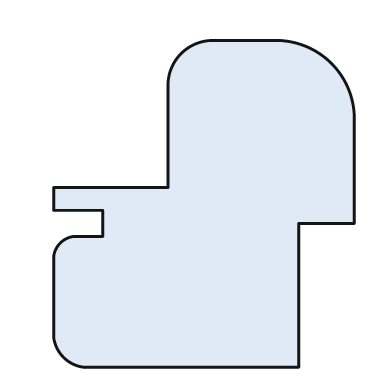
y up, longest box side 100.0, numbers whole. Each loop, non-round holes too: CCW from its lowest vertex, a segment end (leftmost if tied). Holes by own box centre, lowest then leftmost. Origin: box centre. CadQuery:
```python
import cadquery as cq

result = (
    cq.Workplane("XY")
    .moveTo(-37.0, -50.0)
    .lineTo(29.0, -50.0)
    .lineTo(29.0, -6.0)
    .lineTo(46.0, -6.0)
    .lineTo(46.0, 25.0)
    .threePointArc((39.0, 43.0), (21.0, 50.0))
    .lineTo(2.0, 50.0)
    .threePointArc((-7.0, 46.0), (-11.0, 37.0))
    .lineTo(-11.0, 5.0)
    .lineTo(-46.0, 5.0)
    .lineTo(-46.0, -2.0)
    .lineTo(-31.0, -2.0)
    .lineTo(-31.0, -10.0)
    .lineTo(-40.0, -10.0)
    .threePointArc((-44.0, -12.0), (-46.0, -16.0))
    .lineTo(-46.0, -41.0)
    .threePointArc((-43.0, -47.0), (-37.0, -50.0))
    .close()
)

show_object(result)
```